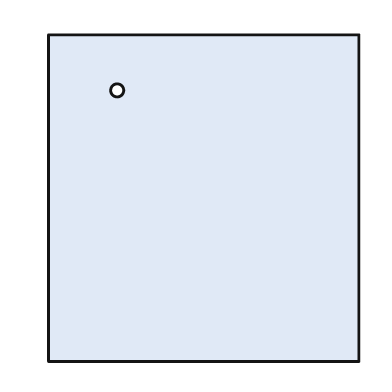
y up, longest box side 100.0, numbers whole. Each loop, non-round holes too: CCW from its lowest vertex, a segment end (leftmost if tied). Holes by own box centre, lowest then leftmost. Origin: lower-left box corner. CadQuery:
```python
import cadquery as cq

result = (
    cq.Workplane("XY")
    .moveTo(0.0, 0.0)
    .lineTo(95.0, 0.0)
    .lineTo(95.0, 100.0)
    .lineTo(0.0, 100.0)
    .close()
    .moveTo(21.0, 83.0)
    .circle(2.0)
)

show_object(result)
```